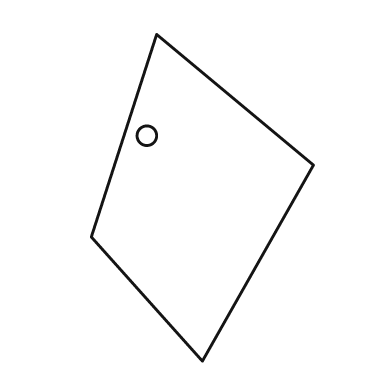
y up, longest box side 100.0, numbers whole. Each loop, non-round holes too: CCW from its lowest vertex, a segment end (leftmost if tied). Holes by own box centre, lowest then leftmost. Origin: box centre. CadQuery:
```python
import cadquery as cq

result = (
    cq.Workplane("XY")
    .moveTo(0.0, -50.0)
    .lineTo(34.0, 10.0)
    .lineTo(-14.0, 50.0)
    .lineTo(-34.0, -12.0)
    .close()
    .moveTo(-17.0, 19.0)
    .circle(3.0)
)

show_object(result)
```